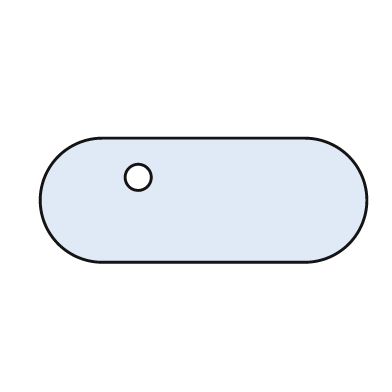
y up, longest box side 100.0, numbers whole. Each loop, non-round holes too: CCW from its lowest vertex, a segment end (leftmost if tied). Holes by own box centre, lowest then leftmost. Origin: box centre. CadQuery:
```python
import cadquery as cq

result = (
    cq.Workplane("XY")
    .moveTo(-31.0, -19.0)
    .lineTo(31.0, -19.0)
    .threePointArc((50.0, 0.0), (31.0, 19.0))
    .lineTo(-31.0, 19.0)
    .threePointArc((-50.0, 0.0), (-31.0, -19.0))
    .close()
    .moveTo(-20.0, 7.0)
    .circle(4.0)
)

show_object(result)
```